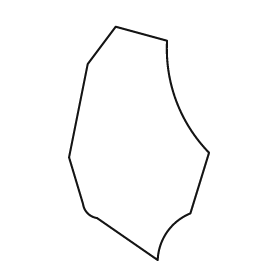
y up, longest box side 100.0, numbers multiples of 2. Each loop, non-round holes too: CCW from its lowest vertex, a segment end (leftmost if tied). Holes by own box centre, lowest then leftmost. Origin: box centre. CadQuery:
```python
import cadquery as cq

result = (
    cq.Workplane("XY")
    .moveTo(8.0, -50.0)
    .threePointArc((12.0, -38.0), (22.0, -30.0))
    .lineTo(30.0, -4.0)
    .threePointArc((16.0, 18.0), (12.0, 44.0))
    .lineTo(-10.0, 50.0)
    .lineTo(-22.0, 34.0)
    .lineTo(-30.0, -6.0)
    .lineTo(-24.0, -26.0)
    .threePointArc((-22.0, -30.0), (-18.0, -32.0))
    .close()
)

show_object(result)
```